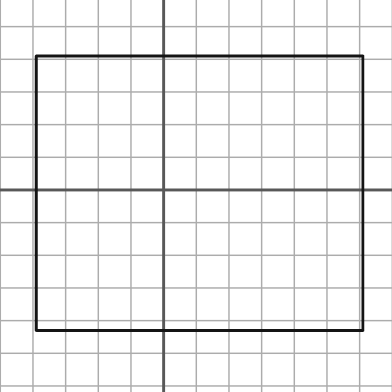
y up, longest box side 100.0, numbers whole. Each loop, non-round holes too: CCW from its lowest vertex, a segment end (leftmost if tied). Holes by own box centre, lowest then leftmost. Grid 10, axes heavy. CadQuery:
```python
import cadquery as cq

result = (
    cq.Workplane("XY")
    .moveTo(-39.0, -43.0)
    .lineTo(61.0, -43.0)
    .lineTo(61.0, 41.0)
    .lineTo(-39.0, 41.0)
    .close()
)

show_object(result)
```